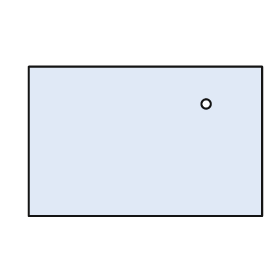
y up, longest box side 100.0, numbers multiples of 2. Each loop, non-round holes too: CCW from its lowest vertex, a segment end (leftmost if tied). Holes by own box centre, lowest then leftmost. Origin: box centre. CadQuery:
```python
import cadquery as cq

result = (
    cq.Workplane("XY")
    .moveTo(-50.0, -32.0)
    .lineTo(50.0, -32.0)
    .lineTo(50.0, 32.0)
    .lineTo(-50.0, 32.0)
    .close()
    .moveTo(26.0, 16.0)
    .circle(2.0)
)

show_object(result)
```